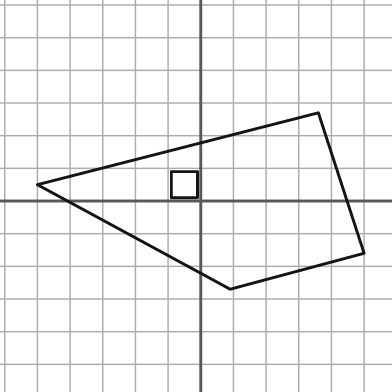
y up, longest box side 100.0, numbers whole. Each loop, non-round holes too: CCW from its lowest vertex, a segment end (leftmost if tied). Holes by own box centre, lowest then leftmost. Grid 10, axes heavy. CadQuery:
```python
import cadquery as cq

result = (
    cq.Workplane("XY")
    .moveTo(9.0, -27.0)
    .lineTo(50.0, -16.0)
    .lineTo(36.0, 27.0)
    .lineTo(-50.0, 5.0)
    .close()
    .moveTo(-9.0, 1.0)
    .lineTo(-1.0, 1.0)
    .lineTo(-1.0, 9.0)
    .lineTo(-9.0, 9.0)
    .close()
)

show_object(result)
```